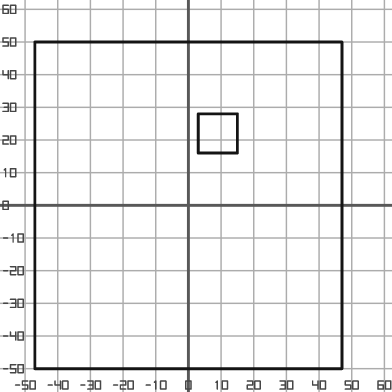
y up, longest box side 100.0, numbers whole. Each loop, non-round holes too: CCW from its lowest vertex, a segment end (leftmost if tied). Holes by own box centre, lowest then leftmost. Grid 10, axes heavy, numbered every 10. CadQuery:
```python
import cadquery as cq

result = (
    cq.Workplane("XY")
    .moveTo(-47.0, -50.0)
    .lineTo(47.0, -50.0)
    .lineTo(47.0, 50.0)
    .lineTo(-47.0, 50.0)
    .close()
    .moveTo(3.0, 16.0)
    .lineTo(15.0, 16.0)
    .lineTo(15.0, 28.0)
    .lineTo(3.0, 28.0)
    .close()
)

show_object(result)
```